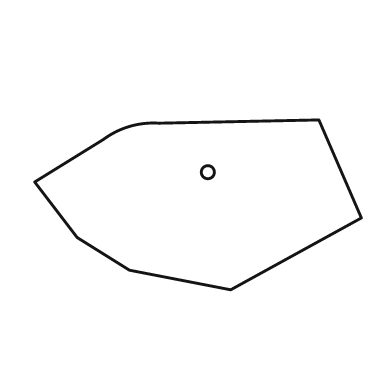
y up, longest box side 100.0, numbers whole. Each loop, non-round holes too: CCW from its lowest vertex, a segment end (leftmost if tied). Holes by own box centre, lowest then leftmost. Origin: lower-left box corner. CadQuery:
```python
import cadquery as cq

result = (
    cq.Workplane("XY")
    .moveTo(60.0, 0.0)
    .lineTo(100.0, 22.0)
    .lineTo(87.0, 52.0)
    .lineTo(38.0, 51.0)
    .threePointArc((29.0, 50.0), (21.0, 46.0))
    .lineTo(0.0, 33.0)
    .lineTo(13.0, 16.0)
    .lineTo(29.0, 6.0)
    .close()
    .moveTo(53.0, 36.0)
    .circle(2.0)
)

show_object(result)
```